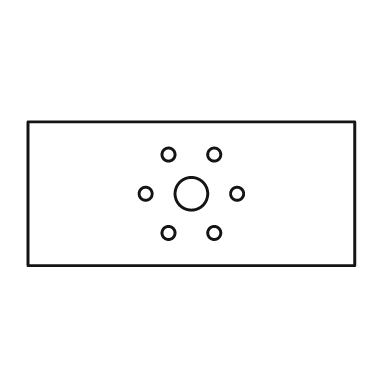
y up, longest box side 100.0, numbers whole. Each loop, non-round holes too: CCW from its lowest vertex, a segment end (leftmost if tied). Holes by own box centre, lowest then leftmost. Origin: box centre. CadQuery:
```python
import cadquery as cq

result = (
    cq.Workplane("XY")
    .moveTo(-50.0, -22.0)
    .lineTo(50.0, -22.0)
    .lineTo(50.0, 22.0)
    .lineTo(-50.0, 22.0)
    .close()
    .moveTo(-7.0, -12.0)
    .circle(2.0)
    .moveTo(7.0, -12.0)
    .circle(2.0)
    .moveTo(-14.0, 0.0)
    .circle(2.0)
    .moveTo(0.0, 0.0)
    .circle(5.0)
    .moveTo(14.0, 0.0)
    .circle(2.0)
    .moveTo(-7.0, 12.0)
    .circle(2.0)
    .moveTo(7.0, 12.0)
    .circle(2.0)
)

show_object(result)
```